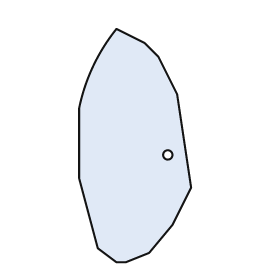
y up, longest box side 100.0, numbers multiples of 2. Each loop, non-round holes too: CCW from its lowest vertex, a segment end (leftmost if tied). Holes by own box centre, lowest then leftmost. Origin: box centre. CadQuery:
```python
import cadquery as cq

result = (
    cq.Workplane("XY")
    .moveTo(-8.0, -50.0)
    .lineTo(-4.0, -50.0)
    .lineTo(6.0, -46.0)
    .lineTo(16.0, -34.0)
    .lineTo(24.0, -18.0)
    .lineTo(18.0, 22.0)
    .lineTo(10.0, 38.0)
    .lineTo(4.0, 44.0)
    .lineTo(-8.0, 50.0)
    .threePointArc((-18.0, 34.0), (-24.0, 16.0))
    .lineTo(-24.0, -14.0)
    .lineTo(-16.0, -44.0)
    .close()
    .moveTo(14.0, -4.0)
    .circle(2.0)
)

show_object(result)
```